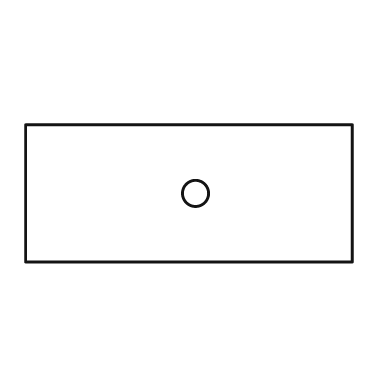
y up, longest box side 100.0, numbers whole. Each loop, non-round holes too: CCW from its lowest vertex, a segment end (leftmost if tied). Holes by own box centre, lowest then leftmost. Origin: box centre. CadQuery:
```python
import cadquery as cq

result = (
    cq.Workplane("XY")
    .moveTo(-50.0, -21.0)
    .lineTo(50.0, -21.0)
    .lineTo(50.0, 21.0)
    .lineTo(-50.0, 21.0)
    .close()
    .moveTo(2.0, 0.0)
    .circle(4.0)
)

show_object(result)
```